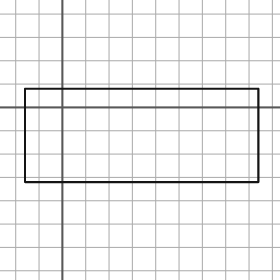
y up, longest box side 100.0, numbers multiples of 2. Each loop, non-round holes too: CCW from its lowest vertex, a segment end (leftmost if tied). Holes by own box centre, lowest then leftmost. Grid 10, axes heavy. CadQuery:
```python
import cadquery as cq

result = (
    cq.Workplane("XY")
    .moveTo(-16.0, -32.0)
    .lineTo(84.0, -32.0)
    .lineTo(84.0, 8.0)
    .lineTo(-16.0, 8.0)
    .close()
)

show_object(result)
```